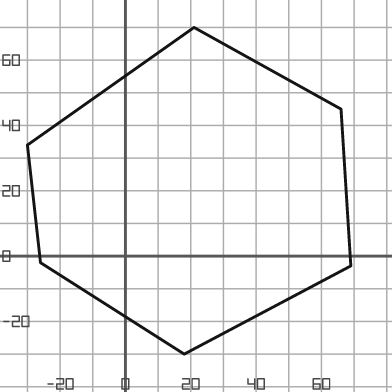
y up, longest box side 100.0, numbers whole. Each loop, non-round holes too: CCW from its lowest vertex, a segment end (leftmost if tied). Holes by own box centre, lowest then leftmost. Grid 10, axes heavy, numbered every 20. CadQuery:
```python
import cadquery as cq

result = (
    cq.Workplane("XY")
    .moveTo(18.0, -30.0)
    .lineTo(69.0, -3.0)
    .lineTo(66.0, 45.0)
    .lineTo(21.0, 70.0)
    .lineTo(-30.0, 34.0)
    .lineTo(-26.0, -2.0)
    .close()
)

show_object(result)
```